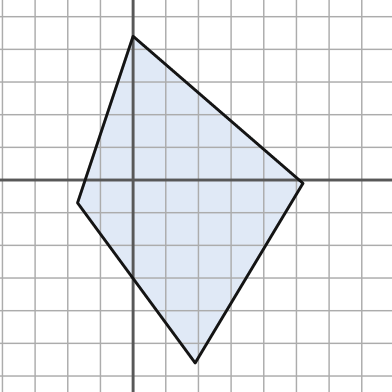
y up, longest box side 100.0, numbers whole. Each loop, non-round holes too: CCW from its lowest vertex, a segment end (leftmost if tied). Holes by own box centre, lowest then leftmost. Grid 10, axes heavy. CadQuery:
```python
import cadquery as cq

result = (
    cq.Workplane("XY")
    .moveTo(19.0, -56.0)
    .lineTo(52.0, -1.0)
    .lineTo(0.0, 44.0)
    .lineTo(-17.0, -7.0)
    .close()
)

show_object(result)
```